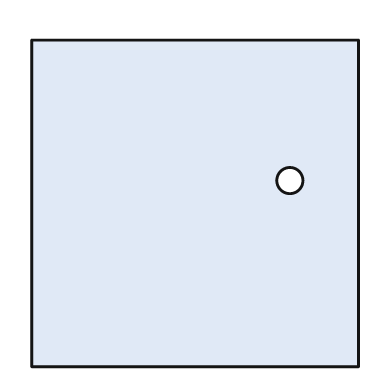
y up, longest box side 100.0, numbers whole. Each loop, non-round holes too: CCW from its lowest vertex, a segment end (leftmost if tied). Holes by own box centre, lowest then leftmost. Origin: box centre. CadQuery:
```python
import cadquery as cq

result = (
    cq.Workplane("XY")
    .moveTo(-50.0, -50.0)
    .lineTo(50.0, -50.0)
    .lineTo(50.0, 50.0)
    .lineTo(-50.0, 50.0)
    .close()
    .moveTo(29.0, 7.0)
    .circle(4.0)
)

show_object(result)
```